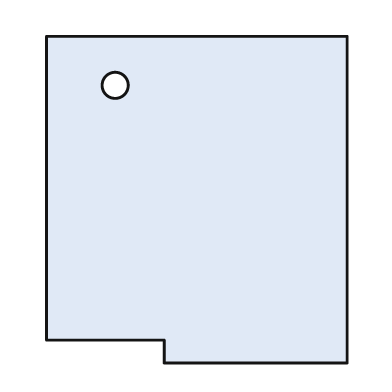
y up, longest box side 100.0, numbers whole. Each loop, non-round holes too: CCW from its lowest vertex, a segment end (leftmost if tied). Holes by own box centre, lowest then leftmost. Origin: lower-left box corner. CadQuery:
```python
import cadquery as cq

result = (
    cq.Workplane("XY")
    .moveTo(36.0, 0.0)
    .lineTo(92.0, 0.0)
    .lineTo(92.0, 100.0)
    .lineTo(0.0, 100.0)
    .lineTo(0.0, 7.0)
    .lineTo(36.0, 7.0)
    .close()
    .moveTo(21.0, 85.0)
    .circle(4.0)
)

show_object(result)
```